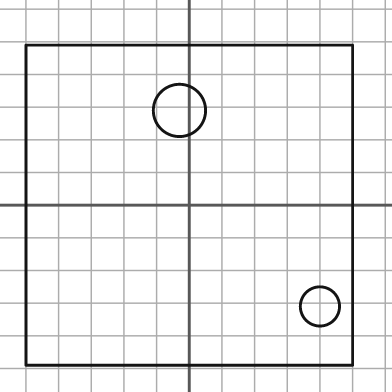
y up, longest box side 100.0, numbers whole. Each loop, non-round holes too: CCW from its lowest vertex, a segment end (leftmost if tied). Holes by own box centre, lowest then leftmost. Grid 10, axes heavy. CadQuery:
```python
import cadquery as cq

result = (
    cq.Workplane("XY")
    .moveTo(-50.0, -49.0)
    .lineTo(50.0, -49.0)
    .lineTo(50.0, 49.0)
    .lineTo(-50.0, 49.0)
    .close()
    .moveTo(40.0, -31.0)
    .circle(6.0)
    .moveTo(-3.0, 29.0)
    .circle(8.0)
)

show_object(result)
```